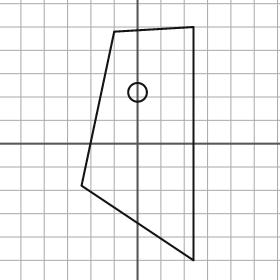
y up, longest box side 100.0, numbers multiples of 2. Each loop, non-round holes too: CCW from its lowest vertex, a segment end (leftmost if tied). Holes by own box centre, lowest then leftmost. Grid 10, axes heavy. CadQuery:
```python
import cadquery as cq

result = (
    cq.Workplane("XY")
    .moveTo(24.0, -50.0)
    .lineTo(24.0, 50.0)
    .lineTo(-10.0, 48.0)
    .lineTo(-24.0, -18.0)
    .close()
    .moveTo(0.0, 22.0)
    .circle(4.0)
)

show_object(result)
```